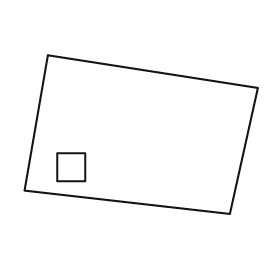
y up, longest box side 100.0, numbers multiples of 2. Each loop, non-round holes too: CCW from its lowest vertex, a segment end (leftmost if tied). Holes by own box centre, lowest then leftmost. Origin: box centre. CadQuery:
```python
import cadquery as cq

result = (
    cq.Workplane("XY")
    .moveTo(38.0, -34.0)
    .lineTo(50.0, 20.0)
    .lineTo(-40.0, 34.0)
    .lineTo(-50.0, -24.0)
    .close()
    .moveTo(-36.0, -20.0)
    .lineTo(-24.0, -20.0)
    .lineTo(-24.0, -8.0)
    .lineTo(-36.0, -8.0)
    .close()
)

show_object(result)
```